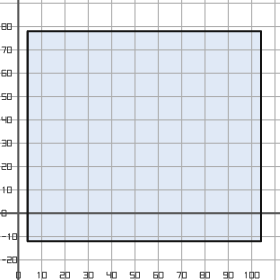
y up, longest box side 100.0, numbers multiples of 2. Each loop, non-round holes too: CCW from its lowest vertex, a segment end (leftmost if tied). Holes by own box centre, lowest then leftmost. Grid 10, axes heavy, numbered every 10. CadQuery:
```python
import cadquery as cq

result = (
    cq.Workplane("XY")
    .moveTo(4.0, -12.0)
    .lineTo(104.0, -12.0)
    .lineTo(104.0, 78.0)
    .lineTo(4.0, 78.0)
    .close()
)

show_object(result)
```